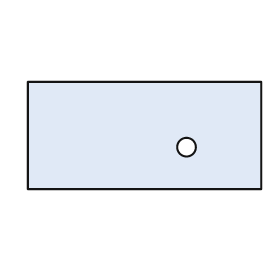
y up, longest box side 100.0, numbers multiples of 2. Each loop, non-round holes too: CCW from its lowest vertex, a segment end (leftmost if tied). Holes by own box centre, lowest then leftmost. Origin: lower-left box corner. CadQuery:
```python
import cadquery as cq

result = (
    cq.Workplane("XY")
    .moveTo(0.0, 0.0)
    .lineTo(100.0, 0.0)
    .lineTo(100.0, 46.0)
    .lineTo(0.0, 46.0)
    .close()
    .moveTo(68.0, 18.0)
    .circle(4.0)
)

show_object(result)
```